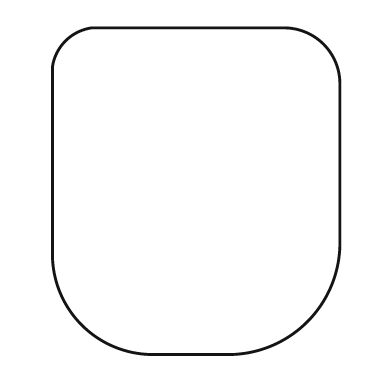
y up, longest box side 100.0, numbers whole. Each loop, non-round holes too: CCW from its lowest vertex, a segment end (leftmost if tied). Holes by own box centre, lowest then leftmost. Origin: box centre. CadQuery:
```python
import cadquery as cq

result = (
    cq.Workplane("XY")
    .moveTo(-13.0, -50.0)
    .lineTo(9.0, -50.0)
    .threePointArc((34.0, -40.0), (44.0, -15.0))
    .lineTo(44.0, 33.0)
    .threePointArc((39.0, 45.0), (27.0, 50.0))
    .lineTo(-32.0, 50.0)
    .threePointArc((-40.0, 46.0), (-44.0, 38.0))
    .lineTo(-44.0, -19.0)
    .threePointArc((-35.0, -41.0), (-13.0, -50.0))
    .close()
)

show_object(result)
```